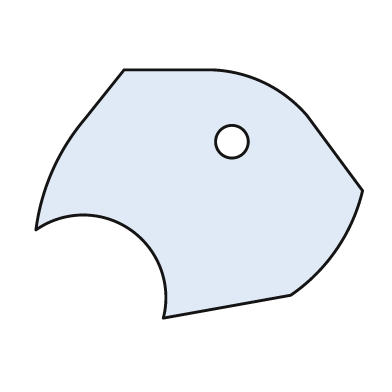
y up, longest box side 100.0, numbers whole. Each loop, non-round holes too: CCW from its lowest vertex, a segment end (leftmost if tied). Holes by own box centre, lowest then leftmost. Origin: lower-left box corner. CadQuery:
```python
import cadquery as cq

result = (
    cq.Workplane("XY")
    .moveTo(39.0, 0.0)
    .lineTo(78.0, 7.0)
    .threePointArc((92.0, 21.0), (100.0, 39.0))
    .lineTo(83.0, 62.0)
    .threePointArc((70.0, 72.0), (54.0, 76.0))
    .lineTo(27.0, 76.0)
    .lineTo(15.0, 61.0)
    .threePointArc((5.0, 45.0), (0.0, 27.0))
    .threePointArc((29.0, 27.0), (39.0, 0.0))
    .close()
    .moveTo(60.0, 54.0)
    .circle(5.0)
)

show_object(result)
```